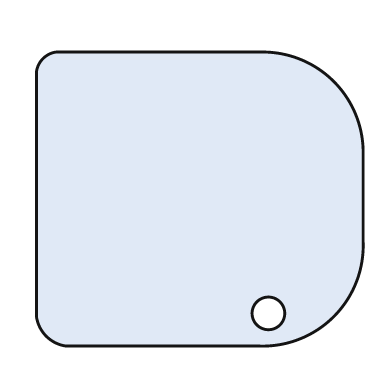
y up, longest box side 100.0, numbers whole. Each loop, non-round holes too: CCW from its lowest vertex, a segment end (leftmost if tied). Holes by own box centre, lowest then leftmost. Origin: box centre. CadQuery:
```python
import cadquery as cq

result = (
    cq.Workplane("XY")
    .moveTo(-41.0, -45.0)
    .lineTo(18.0, -45.0)
    .threePointArc((41.0, -36.0), (50.0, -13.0))
    .lineTo(50.0, 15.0)
    .threePointArc((41.0, 36.0), (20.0, 45.0))
    .lineTo(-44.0, 45.0)
    .threePointArc((-48.0, 43.0), (-50.0, 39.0))
    .lineTo(-50.0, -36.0)
    .threePointArc((-47.0, -42.0), (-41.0, -45.0))
    .close()
    .moveTo(21.0, -35.0)
    .circle(5.0)
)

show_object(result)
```